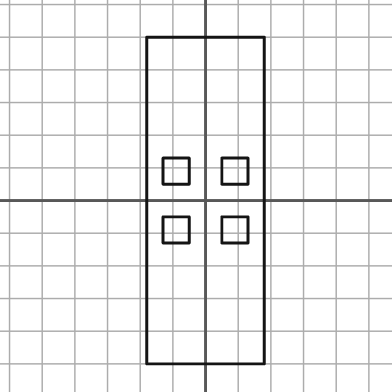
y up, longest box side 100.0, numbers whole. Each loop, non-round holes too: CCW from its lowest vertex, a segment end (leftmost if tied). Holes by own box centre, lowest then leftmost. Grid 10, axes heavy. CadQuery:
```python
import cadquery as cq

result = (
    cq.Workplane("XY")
    .moveTo(-18.0, -50.0)
    .lineTo(18.0, -50.0)
    .lineTo(18.0, 50.0)
    .lineTo(-18.0, 50.0)
    .close()
    .moveTo(-13.0, -13.0)
    .lineTo(-5.0, -13.0)
    .lineTo(-5.0, -5.0)
    .lineTo(-13.0, -5.0)
    .close()
    .moveTo(5.0, -13.0)
    .lineTo(13.0, -13.0)
    .lineTo(13.0, -5.0)
    .lineTo(5.0, -5.0)
    .close()
    .moveTo(-13.0, 5.0)
    .lineTo(-5.0, 5.0)
    .lineTo(-5.0, 13.0)
    .lineTo(-13.0, 13.0)
    .close()
    .moveTo(5.0, 5.0)
    .lineTo(13.0, 5.0)
    .lineTo(13.0, 13.0)
    .lineTo(5.0, 13.0)
    .close()
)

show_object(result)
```